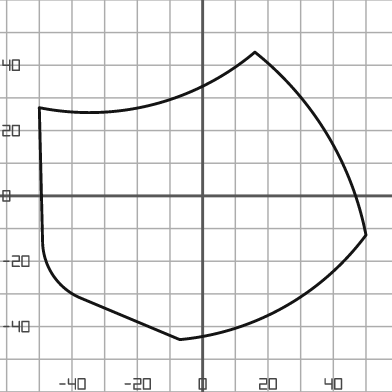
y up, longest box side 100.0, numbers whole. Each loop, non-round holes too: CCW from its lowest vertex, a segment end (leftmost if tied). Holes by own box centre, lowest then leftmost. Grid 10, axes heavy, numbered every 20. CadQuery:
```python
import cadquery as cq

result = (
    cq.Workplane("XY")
    .moveTo(-7.0, -44.0)
    .threePointArc((25.0, -34.0), (50.0, -12.0))
    .threePointArc((38.0, 19.0), (16.0, 44.0))
    .threePointArc((-15.0, 28.0), (-50.0, 27.0))
    .lineTo(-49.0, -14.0)
    .threePointArc((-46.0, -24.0), (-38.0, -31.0))
    .close()
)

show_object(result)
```